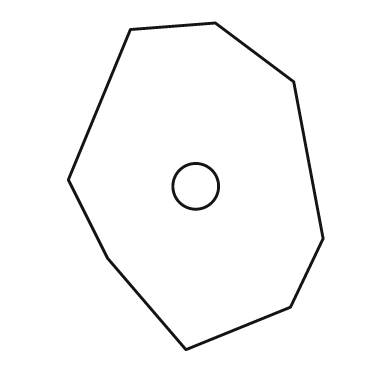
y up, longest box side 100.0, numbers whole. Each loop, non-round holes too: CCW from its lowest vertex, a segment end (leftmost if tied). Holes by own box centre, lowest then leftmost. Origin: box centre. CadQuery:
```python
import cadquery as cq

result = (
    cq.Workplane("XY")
    .moveTo(-3.0, -50.0)
    .lineTo(29.0, -37.0)
    .lineTo(39.0, -16.0)
    .lineTo(30.0, 32.0)
    .lineTo(6.0, 50.0)
    .lineTo(-20.0, 48.0)
    .lineTo(-39.0, 2.0)
    .lineTo(-27.0, -22.0)
    .close()
    .moveTo(0.0, 0.0)
    .circle(7.0)
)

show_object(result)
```